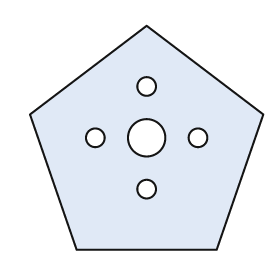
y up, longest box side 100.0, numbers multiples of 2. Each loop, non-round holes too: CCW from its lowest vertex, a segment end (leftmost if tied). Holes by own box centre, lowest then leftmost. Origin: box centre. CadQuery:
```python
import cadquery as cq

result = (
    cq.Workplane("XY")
    .moveTo(-30.0, -48.0)
    .lineTo(30.0, -48.0)
    .lineTo(50.0, 10.0)
    .lineTo(0.0, 48.0)
    .lineTo(-50.0, 10.0)
    .close()
    .moveTo(0.0, -22.0)
    .circle(4.0)
    .moveTo(-22.0, 0.0)
    .circle(4.0)
    .moveTo(0.0, 0.0)
    .circle(8.0)
    .moveTo(22.0, 0.0)
    .circle(4.0)
    .moveTo(0.0, 22.0)
    .circle(4.0)
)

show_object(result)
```